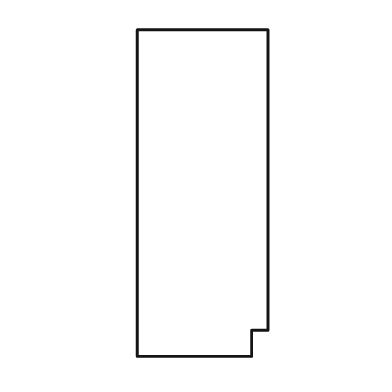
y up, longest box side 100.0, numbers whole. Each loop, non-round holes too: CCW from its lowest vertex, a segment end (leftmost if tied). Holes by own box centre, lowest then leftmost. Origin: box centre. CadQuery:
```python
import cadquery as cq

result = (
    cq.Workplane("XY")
    .moveTo(-20.0, -50.0)
    .lineTo(15.0, -50.0)
    .lineTo(15.0, -42.0)
    .lineTo(20.0, -42.0)
    .lineTo(20.0, 50.0)
    .lineTo(-20.0, 50.0)
    .close()
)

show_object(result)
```